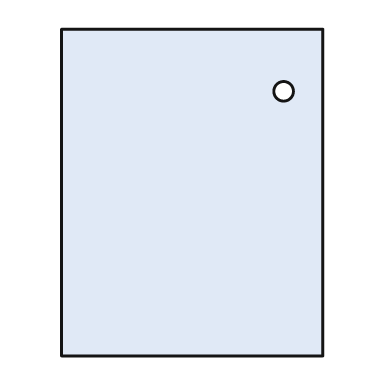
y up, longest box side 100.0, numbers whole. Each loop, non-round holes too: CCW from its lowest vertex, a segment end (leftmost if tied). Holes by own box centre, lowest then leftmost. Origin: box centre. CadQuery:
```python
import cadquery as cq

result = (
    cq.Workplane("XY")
    .moveTo(-40.0, -50.0)
    .lineTo(40.0, -50.0)
    .lineTo(40.0, 50.0)
    .lineTo(-40.0, 50.0)
    .close()
    .moveTo(28.0, 31.0)
    .circle(3.0)
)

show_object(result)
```